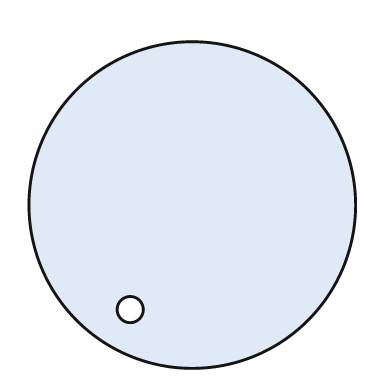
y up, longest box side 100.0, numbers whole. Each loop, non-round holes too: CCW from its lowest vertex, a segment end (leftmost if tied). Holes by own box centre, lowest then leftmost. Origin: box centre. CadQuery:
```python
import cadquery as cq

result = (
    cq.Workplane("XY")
    .moveTo(0.0, 0.0)
    .circle(50.0)
    .moveTo(-19.0, -32.0)
    .circle(4.0)
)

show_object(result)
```